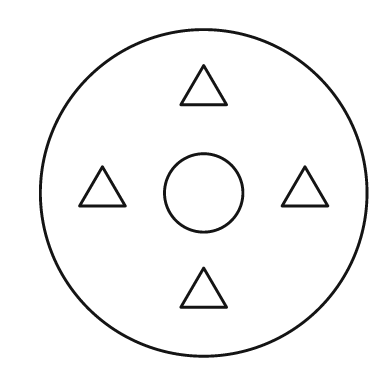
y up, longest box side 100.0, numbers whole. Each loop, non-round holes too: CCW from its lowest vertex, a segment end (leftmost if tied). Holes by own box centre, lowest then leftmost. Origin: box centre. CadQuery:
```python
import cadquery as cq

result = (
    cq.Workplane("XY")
    .moveTo(0.0, 0.0)
    .circle(50.0)
    .moveTo(-7.0, -35.0)
    .lineTo(7.0, -35.0)
    .lineTo(0.0, -23.0)
    .close()
    .moveTo(0.0, 0.0)
    .circle(12.0)
    .moveTo(-38.0, -4.0)
    .lineTo(-24.0, -4.0)
    .lineTo(-31.0, 8.0)
    .close()
    .moveTo(24.0, -4.0)
    .lineTo(38.0, -4.0)
    .lineTo(31.0, 8.0)
    .close()
    .moveTo(-7.0, 27.0)
    .lineTo(7.0, 27.0)
    .lineTo(0.0, 39.0)
    .close()
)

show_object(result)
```